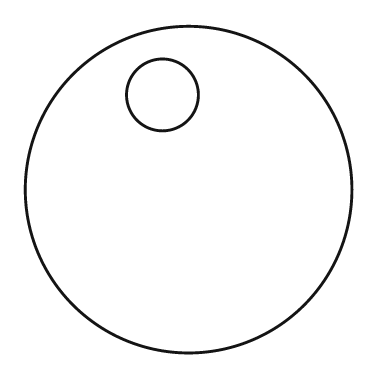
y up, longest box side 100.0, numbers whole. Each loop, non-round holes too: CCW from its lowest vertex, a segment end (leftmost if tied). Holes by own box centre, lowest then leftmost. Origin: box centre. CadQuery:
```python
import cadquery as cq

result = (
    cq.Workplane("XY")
    .moveTo(0.0, 0.0)
    .circle(50.0)
    .moveTo(-8.0, 29.0)
    .circle(11.0)
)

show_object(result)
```